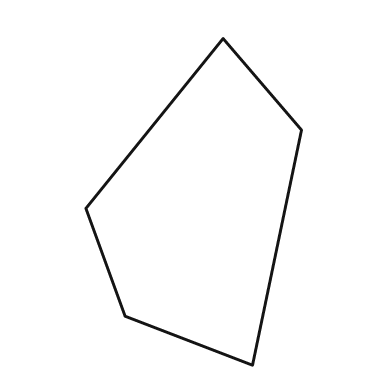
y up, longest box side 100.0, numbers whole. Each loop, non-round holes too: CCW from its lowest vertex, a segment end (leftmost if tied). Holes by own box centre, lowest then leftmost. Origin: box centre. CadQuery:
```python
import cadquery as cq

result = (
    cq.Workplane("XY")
    .moveTo(18.0, -50.0)
    .lineTo(33.0, 22.0)
    .lineTo(9.0, 50.0)
    .lineTo(-33.0, -2.0)
    .lineTo(-21.0, -35.0)
    .close()
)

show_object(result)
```